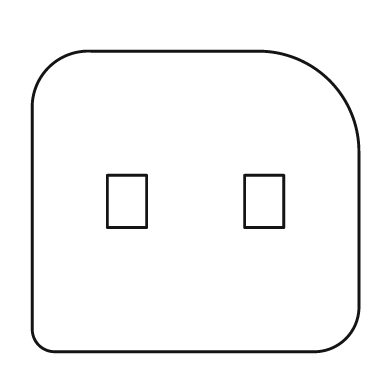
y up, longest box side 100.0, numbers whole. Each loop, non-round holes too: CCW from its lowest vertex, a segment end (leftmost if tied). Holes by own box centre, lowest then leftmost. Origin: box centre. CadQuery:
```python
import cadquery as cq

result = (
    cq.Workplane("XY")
    .moveTo(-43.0, -46.0)
    .lineTo(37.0, -46.0)
    .threePointArc((46.0, -42.0), (50.0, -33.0))
    .lineTo(50.0, 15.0)
    .threePointArc((41.0, 37.0), (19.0, 46.0))
    .lineTo(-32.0, 46.0)
    .threePointArc((-45.0, 41.0), (-50.0, 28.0))
    .lineTo(-50.0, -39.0)
    .threePointArc((-48.0, -44.0), (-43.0, -46.0))
    .close()
    .moveTo(-27.0, -8.0)
    .lineTo(-15.0, -8.0)
    .lineTo(-15.0, 8.0)
    .lineTo(-27.0, 8.0)
    .close()
    .moveTo(15.0, -8.0)
    .lineTo(27.0, -8.0)
    .lineTo(27.0, 8.0)
    .lineTo(15.0, 8.0)
    .close()
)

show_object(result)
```